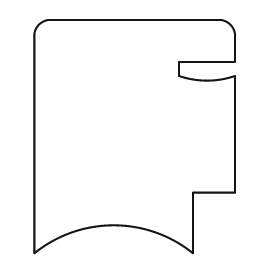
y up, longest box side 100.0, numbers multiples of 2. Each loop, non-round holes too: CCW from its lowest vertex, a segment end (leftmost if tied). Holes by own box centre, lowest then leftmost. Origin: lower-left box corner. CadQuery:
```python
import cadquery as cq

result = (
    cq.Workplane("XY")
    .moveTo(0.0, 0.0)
    .threePointArc((34.0, 12.0), (68.0, 0.0))
    .lineTo(68.0, 26.0)
    .lineTo(86.0, 26.0)
    .lineTo(86.0, 76.0)
    .threePointArc((74.0, 74.0), (62.0, 76.0))
    .lineTo(62.0, 82.0)
    .lineTo(86.0, 82.0)
    .lineTo(86.0, 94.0)
    .threePointArc((84.0, 98.0), (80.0, 100.0))
    .lineTo(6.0, 100.0)
    .threePointArc((2.0, 98.0), (0.0, 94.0))
    .close()
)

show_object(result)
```